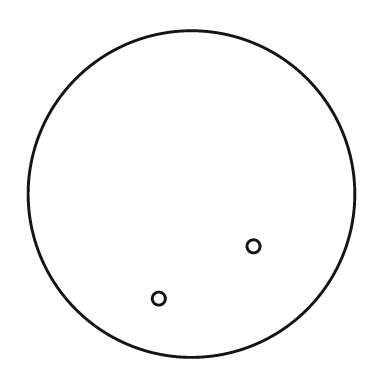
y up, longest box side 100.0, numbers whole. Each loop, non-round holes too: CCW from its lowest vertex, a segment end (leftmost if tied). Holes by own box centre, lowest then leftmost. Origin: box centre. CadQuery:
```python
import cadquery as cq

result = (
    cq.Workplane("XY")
    .moveTo(0.0, 0.0)
    .circle(50.0)
    .moveTo(-10.0, -32.0)
    .circle(2.0)
    .moveTo(19.0, -16.0)
    .circle(2.0)
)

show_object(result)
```